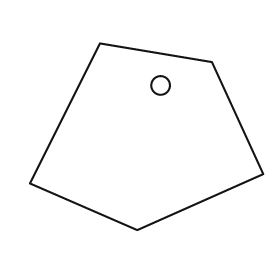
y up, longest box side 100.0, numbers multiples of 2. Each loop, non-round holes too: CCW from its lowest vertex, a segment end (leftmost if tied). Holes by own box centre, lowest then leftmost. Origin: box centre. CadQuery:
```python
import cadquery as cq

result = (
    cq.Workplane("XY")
    .moveTo(-4.0, -40.0)
    .lineTo(50.0, -16.0)
    .lineTo(28.0, 32.0)
    .lineTo(-20.0, 40.0)
    .lineTo(-50.0, -20.0)
    .close()
    .moveTo(6.0, 22.0)
    .circle(4.0)
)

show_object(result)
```